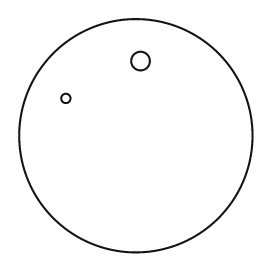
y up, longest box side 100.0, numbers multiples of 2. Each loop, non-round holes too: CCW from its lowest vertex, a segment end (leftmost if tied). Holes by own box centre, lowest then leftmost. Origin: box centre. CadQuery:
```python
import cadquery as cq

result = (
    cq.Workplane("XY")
    .moveTo(0.0, 0.0)
    .circle(50.0)
    .moveTo(-30.0, 16.0)
    .circle(2.0)
    .moveTo(2.0, 32.0)
    .circle(4.0)
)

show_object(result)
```